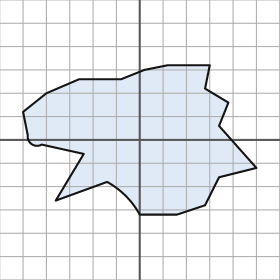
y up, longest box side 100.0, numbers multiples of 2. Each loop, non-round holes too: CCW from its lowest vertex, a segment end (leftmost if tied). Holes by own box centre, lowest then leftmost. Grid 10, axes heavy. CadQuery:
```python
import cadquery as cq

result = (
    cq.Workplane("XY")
    .moveTo(0.0, -32.0)
    .lineTo(16.0, -32.0)
    .lineTo(28.0, -28.0)
    .lineTo(34.0, -16.0)
    .lineTo(50.0, -12.0)
    .lineTo(34.0, 6.0)
    .lineTo(38.0, 16.0)
    .lineTo(28.0, 22.0)
    .lineTo(30.0, 32.0)
    .lineTo(12.0, 32.0)
    .lineTo(2.0, 30.0)
    .lineTo(-8.0, 26.0)
    .lineTo(-26.0, 26.0)
    .lineTo(-40.0, 20.0)
    .lineTo(-50.0, 12.0)
    .lineTo(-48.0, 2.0)
    .threePointArc((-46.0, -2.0), (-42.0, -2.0))
    .lineTo(-24.0, -6.0)
    .lineTo(-36.0, -26.0)
    .lineTo(-14.0, -18.0)
    .threePointArc((-6.0, -24.0), (0.0, -32.0))
    .close()
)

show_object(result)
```